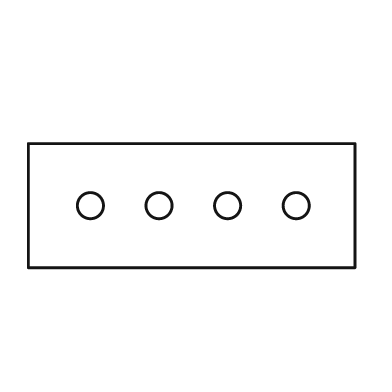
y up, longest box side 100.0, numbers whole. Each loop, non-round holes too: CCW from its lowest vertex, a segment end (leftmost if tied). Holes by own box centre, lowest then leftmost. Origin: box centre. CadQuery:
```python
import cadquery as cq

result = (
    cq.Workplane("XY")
    .moveTo(-50.0, -19.0)
    .lineTo(50.0, -19.0)
    .lineTo(50.0, 19.0)
    .lineTo(-50.0, 19.0)
    .close()
    .moveTo(-31.0, 0.0)
    .circle(4.0)
    .moveTo(-10.0, 0.0)
    .circle(4.0)
    .moveTo(11.0, 0.0)
    .circle(4.0)
    .moveTo(32.0, 0.0)
    .circle(4.0)
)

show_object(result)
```